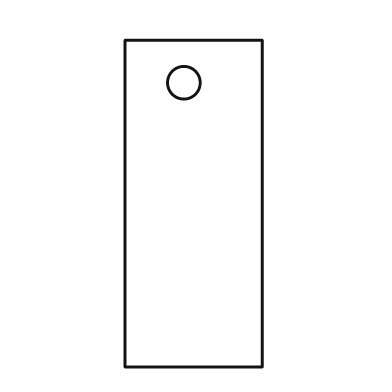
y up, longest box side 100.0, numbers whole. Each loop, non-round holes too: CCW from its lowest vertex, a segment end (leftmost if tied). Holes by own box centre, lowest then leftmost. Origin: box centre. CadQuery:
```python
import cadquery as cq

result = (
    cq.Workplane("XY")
    .moveTo(-21.0, -50.0)
    .lineTo(21.0, -50.0)
    .lineTo(21.0, 50.0)
    .lineTo(-21.0, 50.0)
    .close()
    .moveTo(-3.0, 37.0)
    .circle(5.0)
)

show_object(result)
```